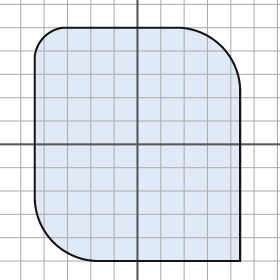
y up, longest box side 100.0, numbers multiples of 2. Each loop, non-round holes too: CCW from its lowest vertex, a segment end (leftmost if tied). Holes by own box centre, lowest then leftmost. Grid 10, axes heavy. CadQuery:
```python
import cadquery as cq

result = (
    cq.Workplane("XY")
    .moveTo(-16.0, -50.0)
    .lineTo(44.0, -50.0)
    .lineTo(44.0, 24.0)
    .threePointArc((36.0, 42.0), (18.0, 50.0))
    .lineTo(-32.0, 50.0)
    .threePointArc((-40.0, 46.0), (-44.0, 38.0))
    .lineTo(-44.0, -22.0)
    .threePointArc((-36.0, -42.0), (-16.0, -50.0))
    .close()
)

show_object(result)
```